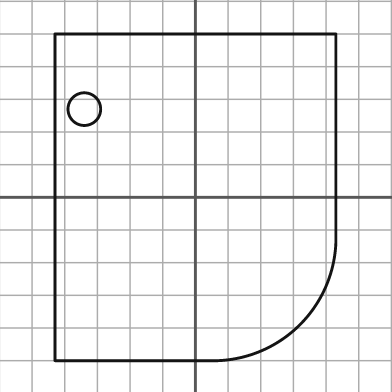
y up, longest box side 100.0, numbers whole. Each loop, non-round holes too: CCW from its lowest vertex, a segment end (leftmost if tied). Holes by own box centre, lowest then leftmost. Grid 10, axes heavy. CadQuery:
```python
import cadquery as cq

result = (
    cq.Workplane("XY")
    .moveTo(-43.0, -50.0)
    .lineTo(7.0, -50.0)
    .threePointArc((32.0, -39.0), (43.0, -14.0))
    .lineTo(43.0, 50.0)
    .lineTo(-43.0, 50.0)
    .close()
    .moveTo(-34.0, 27.0)
    .circle(5.0)
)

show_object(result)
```